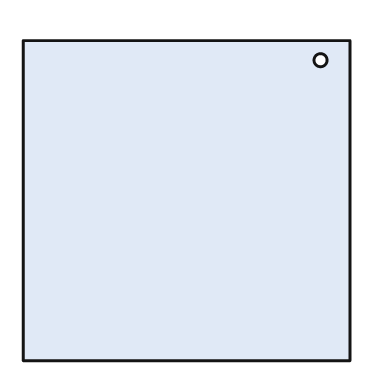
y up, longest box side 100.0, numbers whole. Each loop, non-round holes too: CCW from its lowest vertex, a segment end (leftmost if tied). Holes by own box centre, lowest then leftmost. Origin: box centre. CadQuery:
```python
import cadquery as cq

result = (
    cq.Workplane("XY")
    .moveTo(-50.0, -49.0)
    .lineTo(50.0, -49.0)
    .lineTo(50.0, 49.0)
    .lineTo(-50.0, 49.0)
    .close()
    .moveTo(41.0, 43.0)
    .circle(2.0)
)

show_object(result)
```